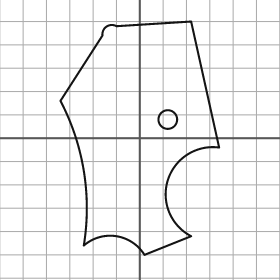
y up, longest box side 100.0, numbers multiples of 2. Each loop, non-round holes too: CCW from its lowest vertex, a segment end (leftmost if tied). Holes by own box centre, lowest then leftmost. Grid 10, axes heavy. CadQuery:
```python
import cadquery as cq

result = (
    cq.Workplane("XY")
    .moveTo(2.0, -50.0)
    .lineTo(22.0, -42.0)
    .threePointArc((12.0, -18.0), (34.0, -4.0))
    .lineTo(22.0, 50.0)
    .lineTo(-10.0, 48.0)
    .threePointArc((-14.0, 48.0), (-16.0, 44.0))
    .lineTo(-34.0, 16.0)
    .threePointArc((-24.0, -14.0), (-24.0, -46.0))
    .threePointArc((-10.0, -42.0), (2.0, -50.0))
    .close()
    .moveTo(12.0, 8.0)
    .circle(4.0)
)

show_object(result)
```